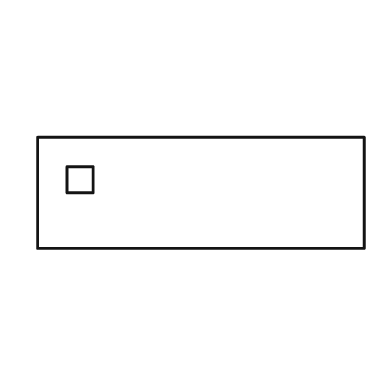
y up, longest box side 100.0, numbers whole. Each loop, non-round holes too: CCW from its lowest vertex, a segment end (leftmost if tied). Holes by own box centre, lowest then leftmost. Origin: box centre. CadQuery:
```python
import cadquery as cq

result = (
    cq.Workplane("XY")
    .moveTo(-50.0, -17.0)
    .lineTo(50.0, -17.0)
    .lineTo(50.0, 17.0)
    .lineTo(-50.0, 17.0)
    .close()
    .moveTo(-41.0, 0.0)
    .lineTo(-33.0, 0.0)
    .lineTo(-33.0, 8.0)
    .lineTo(-41.0, 8.0)
    .close()
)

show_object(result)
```